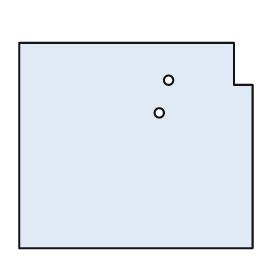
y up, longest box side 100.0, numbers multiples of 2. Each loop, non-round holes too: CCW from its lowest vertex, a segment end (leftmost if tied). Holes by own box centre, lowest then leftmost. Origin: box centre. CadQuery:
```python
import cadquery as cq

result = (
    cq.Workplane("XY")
    .moveTo(-50.0, -44.0)
    .lineTo(50.0, -44.0)
    .lineTo(50.0, 26.0)
    .lineTo(42.0, 26.0)
    .lineTo(42.0, 44.0)
    .lineTo(-50.0, 44.0)
    .close()
    .moveTo(10.0, 14.0)
    .circle(2.0)
    .moveTo(14.0, 28.0)
    .circle(2.0)
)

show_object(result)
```